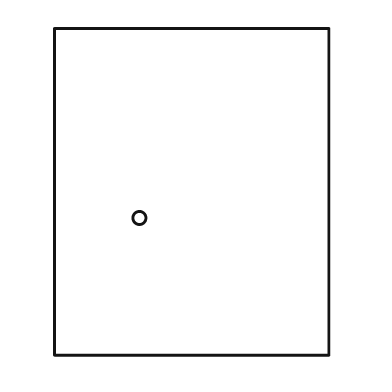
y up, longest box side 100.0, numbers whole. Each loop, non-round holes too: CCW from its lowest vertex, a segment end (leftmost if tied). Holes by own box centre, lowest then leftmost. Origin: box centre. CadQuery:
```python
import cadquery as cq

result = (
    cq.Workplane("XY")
    .moveTo(-42.0, -50.0)
    .lineTo(42.0, -50.0)
    .lineTo(42.0, 50.0)
    .lineTo(-42.0, 50.0)
    .close()
    .moveTo(-16.0, -8.0)
    .circle(2.0)
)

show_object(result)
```